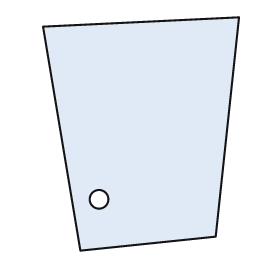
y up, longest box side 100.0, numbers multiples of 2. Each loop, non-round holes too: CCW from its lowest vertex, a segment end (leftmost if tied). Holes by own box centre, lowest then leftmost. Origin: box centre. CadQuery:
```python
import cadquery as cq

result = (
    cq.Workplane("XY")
    .moveTo(-26.0, -50.0)
    .lineTo(32.0, -44.0)
    .lineTo(42.0, 50.0)
    .lineTo(-42.0, 46.0)
    .close()
    .moveTo(-18.0, -28.0)
    .circle(4.0)
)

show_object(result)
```